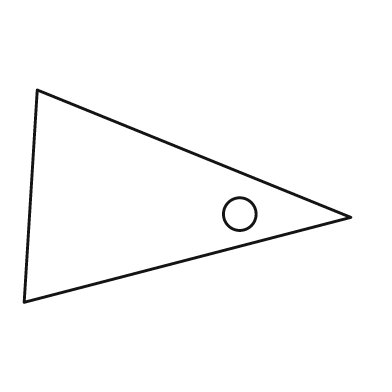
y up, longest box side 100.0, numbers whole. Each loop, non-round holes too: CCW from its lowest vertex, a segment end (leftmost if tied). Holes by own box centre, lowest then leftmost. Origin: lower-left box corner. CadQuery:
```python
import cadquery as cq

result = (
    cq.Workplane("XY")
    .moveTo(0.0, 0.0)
    .lineTo(100.0, 26.0)
    .lineTo(4.0, 65.0)
    .close()
    .moveTo(66.0, 27.0)
    .circle(5.0)
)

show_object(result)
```